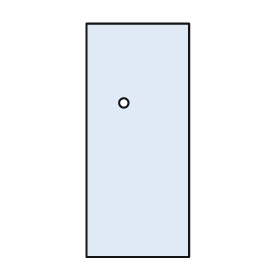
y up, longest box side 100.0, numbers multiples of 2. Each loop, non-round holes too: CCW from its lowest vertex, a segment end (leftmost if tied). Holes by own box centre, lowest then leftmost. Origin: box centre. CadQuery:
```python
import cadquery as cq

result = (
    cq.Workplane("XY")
    .moveTo(-22.0, -50.0)
    .lineTo(22.0, -50.0)
    .lineTo(22.0, 50.0)
    .lineTo(-22.0, 50.0)
    .close()
    .moveTo(-6.0, 16.0)
    .circle(2.0)
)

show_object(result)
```